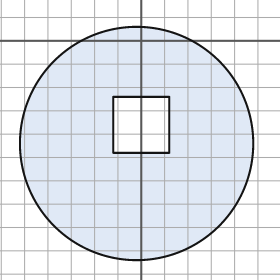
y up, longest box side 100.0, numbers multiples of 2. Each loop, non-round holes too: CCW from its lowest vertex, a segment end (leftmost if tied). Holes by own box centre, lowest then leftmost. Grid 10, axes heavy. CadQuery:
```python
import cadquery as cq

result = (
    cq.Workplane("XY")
    .moveTo(-2.0, -44.0)
    .circle(50.0)
    .moveTo(-12.0, -48.0)
    .lineTo(12.0, -48.0)
    .lineTo(12.0, -24.0)
    .lineTo(-12.0, -24.0)
    .close()
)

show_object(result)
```